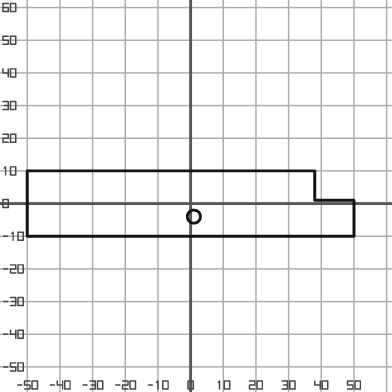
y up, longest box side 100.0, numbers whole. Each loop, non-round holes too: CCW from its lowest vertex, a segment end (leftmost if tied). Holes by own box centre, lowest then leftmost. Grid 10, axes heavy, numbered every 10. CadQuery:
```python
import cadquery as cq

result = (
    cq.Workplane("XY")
    .moveTo(-50.0, -10.0)
    .lineTo(50.0, -10.0)
    .lineTo(50.0, 1.0)
    .lineTo(38.0, 1.0)
    .lineTo(38.0, 10.0)
    .lineTo(-50.0, 10.0)
    .close()
    .moveTo(1.0, -4.0)
    .circle(2.0)
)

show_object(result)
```